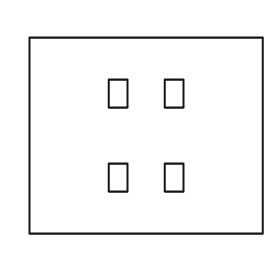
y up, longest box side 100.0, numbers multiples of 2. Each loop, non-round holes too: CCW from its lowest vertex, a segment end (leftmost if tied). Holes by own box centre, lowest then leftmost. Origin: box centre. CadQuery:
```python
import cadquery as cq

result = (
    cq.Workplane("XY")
    .moveTo(-50.0, -42.0)
    .lineTo(50.0, -42.0)
    .lineTo(50.0, 42.0)
    .lineTo(-50.0, 42.0)
    .close()
    .moveTo(-16.0, -24.0)
    .lineTo(-8.0, -24.0)
    .lineTo(-8.0, -12.0)
    .lineTo(-16.0, -12.0)
    .close()
    .moveTo(8.0, -24.0)
    .lineTo(16.0, -24.0)
    .lineTo(16.0, -12.0)
    .lineTo(8.0, -12.0)
    .close()
    .moveTo(-16.0, 12.0)
    .lineTo(-8.0, 12.0)
    .lineTo(-8.0, 24.0)
    .lineTo(-16.0, 24.0)
    .close()
    .moveTo(8.0, 12.0)
    .lineTo(16.0, 12.0)
    .lineTo(16.0, 24.0)
    .lineTo(8.0, 24.0)
    .close()
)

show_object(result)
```